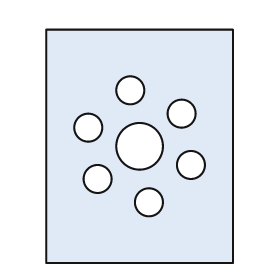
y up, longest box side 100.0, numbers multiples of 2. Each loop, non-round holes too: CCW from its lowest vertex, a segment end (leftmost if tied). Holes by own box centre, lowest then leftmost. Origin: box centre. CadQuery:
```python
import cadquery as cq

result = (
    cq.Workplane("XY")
    .moveTo(-40.0, -50.0)
    .lineTo(40.0, -50.0)
    .lineTo(40.0, 50.0)
    .lineTo(-40.0, 50.0)
    .close()
    .moveTo(4.0, -24.0)
    .circle(6.0)
    .moveTo(-18.0, -14.0)
    .circle(6.0)
    .moveTo(22.0, -8.0)
    .circle(6.0)
    .moveTo(0.0, 0.0)
    .circle(10.0)
    .moveTo(-22.0, 8.0)
    .circle(6.0)
    .moveTo(18.0, 14.0)
    .circle(6.0)
    .moveTo(-4.0, 24.0)
    .circle(6.0)
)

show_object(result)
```